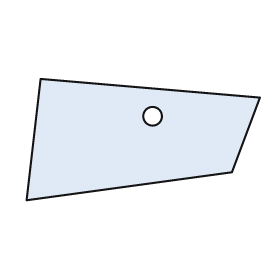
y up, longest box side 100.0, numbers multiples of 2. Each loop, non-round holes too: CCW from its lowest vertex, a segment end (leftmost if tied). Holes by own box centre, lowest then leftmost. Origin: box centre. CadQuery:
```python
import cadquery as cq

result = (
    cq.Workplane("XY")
    .moveTo(-50.0, -26.0)
    .lineTo(38.0, -14.0)
    .lineTo(50.0, 18.0)
    .lineTo(-44.0, 26.0)
    .close()
    .moveTo(4.0, 10.0)
    .circle(4.0)
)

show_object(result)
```